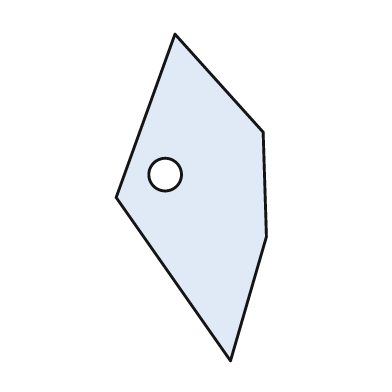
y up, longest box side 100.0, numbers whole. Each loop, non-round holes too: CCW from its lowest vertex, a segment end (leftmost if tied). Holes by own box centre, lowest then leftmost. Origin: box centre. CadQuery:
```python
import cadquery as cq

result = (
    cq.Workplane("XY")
    .moveTo(12.0, -50.0)
    .lineTo(23.0, -12.0)
    .lineTo(22.0, 20.0)
    .lineTo(-5.0, 50.0)
    .lineTo(-23.0, 0.0)
    .close()
    .moveTo(-8.0, 7.0)
    .circle(5.0)
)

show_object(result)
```